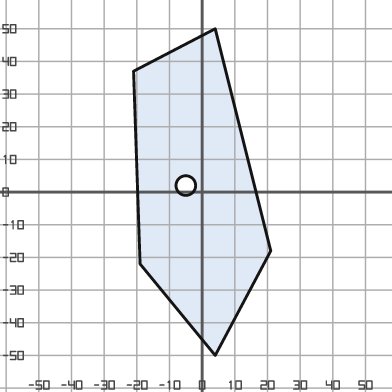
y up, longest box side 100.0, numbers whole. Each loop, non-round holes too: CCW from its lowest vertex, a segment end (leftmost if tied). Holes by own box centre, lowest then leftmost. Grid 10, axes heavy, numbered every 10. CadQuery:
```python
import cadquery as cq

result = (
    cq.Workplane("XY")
    .moveTo(4.0, -50.0)
    .lineTo(21.0, -18.0)
    .lineTo(4.0, 50.0)
    .lineTo(-21.0, 37.0)
    .lineTo(-19.0, -22.0)
    .close()
    .moveTo(-5.0, 2.0)
    .circle(3.0)
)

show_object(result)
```